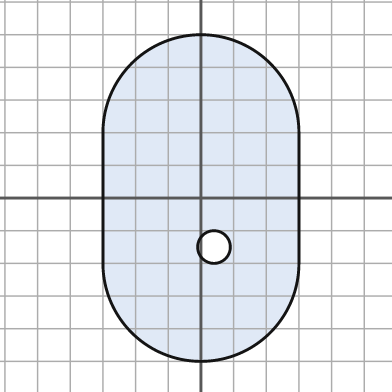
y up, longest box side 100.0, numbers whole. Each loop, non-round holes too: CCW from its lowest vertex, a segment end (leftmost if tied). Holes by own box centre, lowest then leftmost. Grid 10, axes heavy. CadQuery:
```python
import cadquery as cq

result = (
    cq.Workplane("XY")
    .moveTo(-30.0, -20.0)
    .threePointArc((0.0, -50.0), (30.0, -20.0))
    .lineTo(30.0, 20.0)
    .threePointArc((0.0, 50.0), (-30.0, 20.0))
    .close()
    .moveTo(4.0, -15.0)
    .circle(5.0)
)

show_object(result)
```